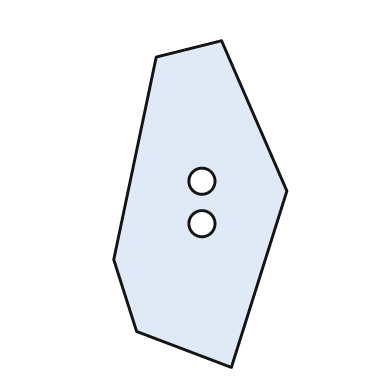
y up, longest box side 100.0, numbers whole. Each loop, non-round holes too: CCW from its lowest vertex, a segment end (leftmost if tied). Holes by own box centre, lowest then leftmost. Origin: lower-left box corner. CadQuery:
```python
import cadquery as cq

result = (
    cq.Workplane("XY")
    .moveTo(36.0, 0.0)
    .lineTo(53.0, 54.0)
    .lineTo(33.0, 100.0)
    .lineTo(13.0, 95.0)
    .lineTo(0.0, 33.0)
    .lineTo(7.0, 11.0)
    .close()
    .moveTo(27.0, 44.0)
    .circle(4.0)
    .moveTo(27.0, 57.0)
    .circle(4.0)
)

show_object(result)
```